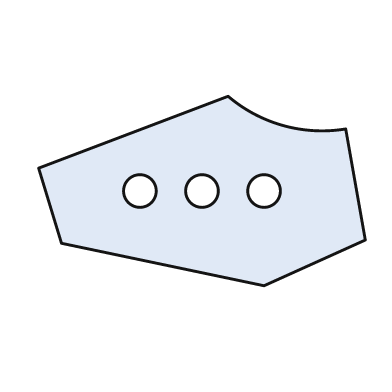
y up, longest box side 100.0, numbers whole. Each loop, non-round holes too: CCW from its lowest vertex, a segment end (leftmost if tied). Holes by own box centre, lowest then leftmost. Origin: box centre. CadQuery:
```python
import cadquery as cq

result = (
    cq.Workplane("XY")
    .moveTo(19.0, -29.0)
    .lineTo(50.0, -15.0)
    .lineTo(44.0, 19.0)
    .threePointArc((25.0, 20.0), (8.0, 29.0))
    .lineTo(-50.0, 7.0)
    .lineTo(-43.0, -16.0)
    .close()
    .moveTo(-19.0, 0.0)
    .circle(5.0)
    .moveTo(0.0, 0.0)
    .circle(5.0)
    .moveTo(19.0, 0.0)
    .circle(5.0)
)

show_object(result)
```